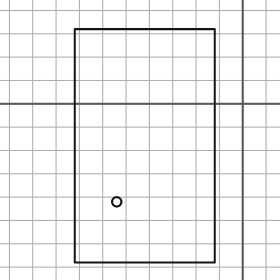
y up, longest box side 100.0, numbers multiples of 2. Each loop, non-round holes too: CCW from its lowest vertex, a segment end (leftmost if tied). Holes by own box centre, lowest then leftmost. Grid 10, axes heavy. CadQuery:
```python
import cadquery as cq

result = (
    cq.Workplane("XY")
    .moveTo(-72.0, -68.0)
    .lineTo(-12.0, -68.0)
    .lineTo(-12.0, 32.0)
    .lineTo(-72.0, 32.0)
    .close()
    .moveTo(-54.0, -42.0)
    .circle(2.0)
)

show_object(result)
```